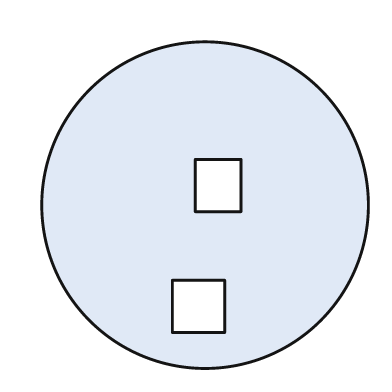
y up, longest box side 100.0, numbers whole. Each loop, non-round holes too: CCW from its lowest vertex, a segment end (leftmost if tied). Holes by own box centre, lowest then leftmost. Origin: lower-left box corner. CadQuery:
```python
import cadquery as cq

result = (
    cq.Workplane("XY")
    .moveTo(50.0, 50.0)
    .circle(50.0)
    .moveTo(40.0, 11.0)
    .lineTo(56.0, 11.0)
    .lineTo(56.0, 27.0)
    .lineTo(40.0, 27.0)
    .close()
    .moveTo(47.0, 48.0)
    .lineTo(61.0, 48.0)
    .lineTo(61.0, 64.0)
    .lineTo(47.0, 64.0)
    .close()
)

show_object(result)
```